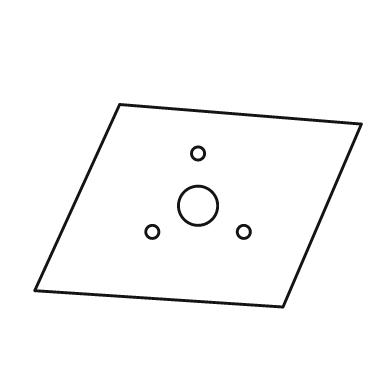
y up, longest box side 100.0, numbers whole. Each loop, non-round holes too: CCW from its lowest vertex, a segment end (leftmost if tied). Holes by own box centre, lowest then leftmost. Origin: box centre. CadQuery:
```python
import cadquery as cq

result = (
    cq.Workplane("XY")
    .moveTo(26.0, -31.0)
    .lineTo(50.0, 25.0)
    .lineTo(-24.0, 31.0)
    .lineTo(-50.0, -26.0)
    .close()
    .moveTo(-14.0, -8.0)
    .circle(2.0)
    .moveTo(14.0, -8.0)
    .circle(2.0)
    .moveTo(0.0, 0.0)
    .circle(6.0)
    .moveTo(0.0, 16.0)
    .circle(2.0)
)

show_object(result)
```